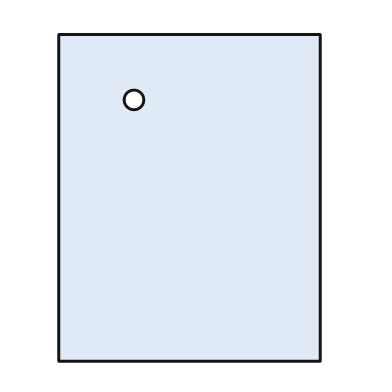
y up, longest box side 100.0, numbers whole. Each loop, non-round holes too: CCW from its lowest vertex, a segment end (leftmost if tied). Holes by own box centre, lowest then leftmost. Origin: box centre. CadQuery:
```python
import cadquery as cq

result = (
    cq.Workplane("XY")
    .moveTo(-40.0, -50.0)
    .lineTo(40.0, -50.0)
    .lineTo(40.0, 50.0)
    .lineTo(-40.0, 50.0)
    .close()
    .moveTo(-17.0, 30.0)
    .circle(3.0)
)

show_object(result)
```